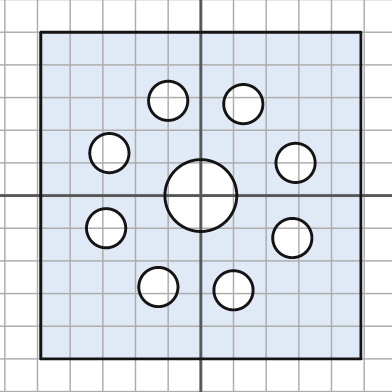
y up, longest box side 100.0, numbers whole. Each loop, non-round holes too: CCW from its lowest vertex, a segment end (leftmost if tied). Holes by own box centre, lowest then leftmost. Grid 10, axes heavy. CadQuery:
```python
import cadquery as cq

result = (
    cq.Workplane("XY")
    .moveTo(-49.0, -50.0)
    .lineTo(49.0, -50.0)
    .lineTo(49.0, 50.0)
    .lineTo(-49.0, 50.0)
    .close()
    .moveTo(10.0, -29.0)
    .circle(6.0)
    .moveTo(-13.0, -28.0)
    .circle(6.0)
    .moveTo(28.0, -13.0)
    .circle(6.0)
    .moveTo(-29.0, -10.0)
    .circle(6.0)
    .moveTo(0.0, 0.0)
    .circle(11.0)
    .moveTo(29.0, 10.0)
    .circle(6.0)
    .moveTo(-28.0, 13.0)
    .circle(6.0)
    .moveTo(13.0, 28.0)
    .circle(6.0)
    .moveTo(-10.0, 29.0)
    .circle(6.0)
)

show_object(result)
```